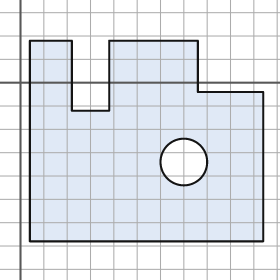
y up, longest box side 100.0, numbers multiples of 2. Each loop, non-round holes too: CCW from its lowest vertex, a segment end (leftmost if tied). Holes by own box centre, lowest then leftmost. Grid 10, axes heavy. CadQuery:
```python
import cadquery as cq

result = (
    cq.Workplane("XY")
    .moveTo(4.0, -68.0)
    .lineTo(104.0, -68.0)
    .lineTo(104.0, -4.0)
    .lineTo(76.0, -4.0)
    .lineTo(76.0, 18.0)
    .lineTo(38.0, 18.0)
    .lineTo(38.0, -12.0)
    .lineTo(22.0, -12.0)
    .lineTo(22.0, 18.0)
    .lineTo(4.0, 18.0)
    .close()
    .moveTo(70.0, -34.0)
    .circle(10.0)
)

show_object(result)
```